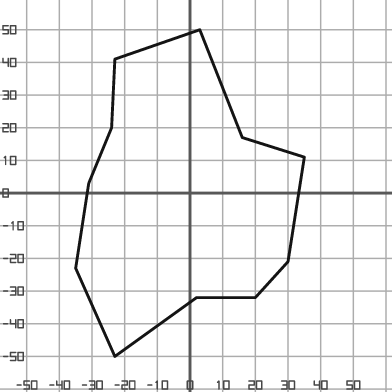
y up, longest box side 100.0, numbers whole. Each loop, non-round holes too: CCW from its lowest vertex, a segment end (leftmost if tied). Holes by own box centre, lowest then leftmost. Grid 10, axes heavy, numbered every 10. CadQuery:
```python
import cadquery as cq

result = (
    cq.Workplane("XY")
    .moveTo(-23.0, -50.0)
    .lineTo(2.0, -32.0)
    .lineTo(20.0, -32.0)
    .lineTo(30.0, -21.0)
    .lineTo(35.0, 11.0)
    .lineTo(16.0, 17.0)
    .lineTo(3.0, 50.0)
    .lineTo(-23.0, 41.0)
    .lineTo(-24.0, 20.0)
    .lineTo(-31.0, 3.0)
    .lineTo(-35.0, -23.0)
    .close()
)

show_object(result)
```